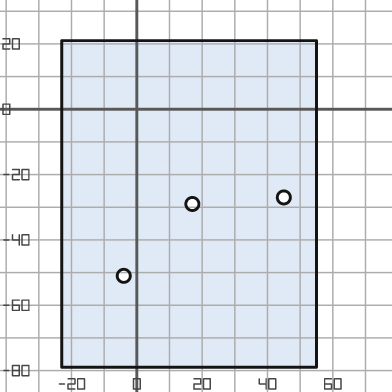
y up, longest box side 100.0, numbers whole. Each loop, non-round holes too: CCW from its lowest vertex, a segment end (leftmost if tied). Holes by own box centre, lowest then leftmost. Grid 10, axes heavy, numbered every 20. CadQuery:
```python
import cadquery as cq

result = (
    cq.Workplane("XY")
    .moveTo(-23.0, -79.0)
    .lineTo(55.0, -79.0)
    .lineTo(55.0, 21.0)
    .lineTo(-23.0, 21.0)
    .close()
    .moveTo(-4.0, -51.0)
    .circle(2.0)
    .moveTo(17.0, -29.0)
    .circle(2.0)
    .moveTo(45.0, -27.0)
    .circle(2.0)
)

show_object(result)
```